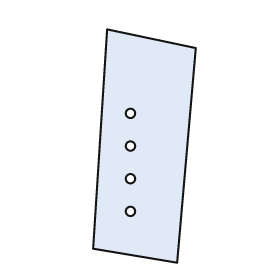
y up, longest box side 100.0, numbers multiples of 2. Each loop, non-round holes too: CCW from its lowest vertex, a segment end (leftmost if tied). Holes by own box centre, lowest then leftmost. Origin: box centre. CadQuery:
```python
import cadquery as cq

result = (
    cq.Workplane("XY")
    .moveTo(14.0, -50.0)
    .lineTo(22.0, 42.0)
    .lineTo(-16.0, 50.0)
    .lineTo(-22.0, -44.0)
    .close()
    .moveTo(-6.0, -28.0)
    .circle(2.0)
    .moveTo(-6.0, -14.0)
    .circle(2.0)
    .moveTo(-6.0, 0.0)
    .circle(2.0)
    .moveTo(-6.0, 14.0)
    .circle(2.0)
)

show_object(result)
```